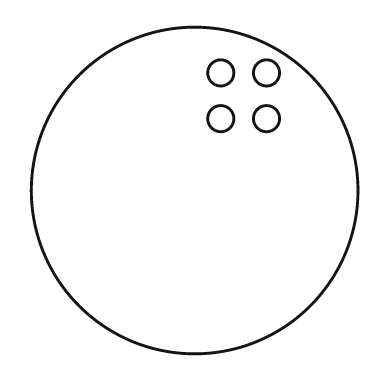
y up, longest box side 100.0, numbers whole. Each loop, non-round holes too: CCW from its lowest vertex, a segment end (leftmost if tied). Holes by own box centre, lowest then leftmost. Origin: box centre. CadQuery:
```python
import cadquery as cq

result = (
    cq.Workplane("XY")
    .moveTo(0.0, 0.0)
    .circle(50.0)
    .moveTo(8.0, 22.0)
    .circle(4.0)
    .moveTo(22.0, 22.0)
    .circle(4.0)
    .moveTo(8.0, 36.0)
    .circle(4.0)
    .moveTo(22.0, 36.0)
    .circle(4.0)
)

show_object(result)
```